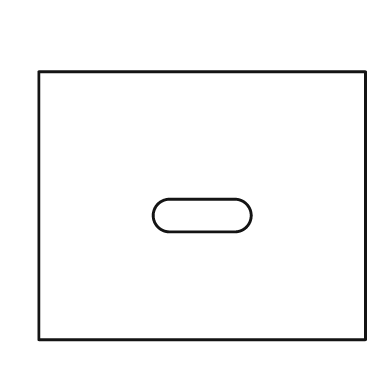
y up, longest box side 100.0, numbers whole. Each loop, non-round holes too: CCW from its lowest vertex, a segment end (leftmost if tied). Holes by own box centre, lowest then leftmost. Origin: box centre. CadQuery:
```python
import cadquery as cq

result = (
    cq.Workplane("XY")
    .moveTo(-50.0, -41.0)
    .lineTo(50.0, -41.0)
    .lineTo(50.0, 41.0)
    .lineTo(-50.0, 41.0)
    .close()
    .moveTo(-10.0, -8.0)
    .lineTo(10.0, -8.0)
    .threePointArc((15.0, -3.0), (10.0, 2.0))
    .lineTo(-10.0, 2.0)
    .threePointArc((-15.0, -3.0), (-10.0, -8.0))
    .close()
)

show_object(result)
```